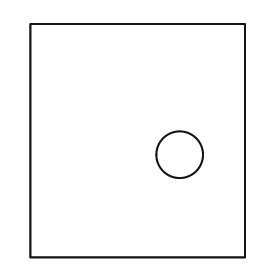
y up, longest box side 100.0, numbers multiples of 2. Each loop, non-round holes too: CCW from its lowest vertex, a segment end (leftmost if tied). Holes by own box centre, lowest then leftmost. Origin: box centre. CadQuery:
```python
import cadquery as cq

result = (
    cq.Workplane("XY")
    .moveTo(-46.0, -50.0)
    .lineTo(46.0, -50.0)
    .lineTo(46.0, 50.0)
    .lineTo(-46.0, 50.0)
    .close()
    .moveTo(18.0, -6.0)
    .circle(10.0)
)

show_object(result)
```